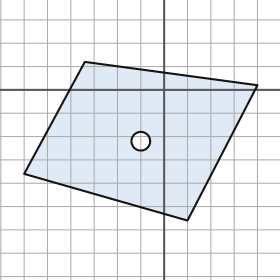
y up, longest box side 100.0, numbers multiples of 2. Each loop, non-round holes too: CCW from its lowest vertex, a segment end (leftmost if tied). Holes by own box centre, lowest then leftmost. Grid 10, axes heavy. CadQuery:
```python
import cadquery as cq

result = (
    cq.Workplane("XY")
    .moveTo(10.0, -56.0)
    .lineTo(40.0, 2.0)
    .lineTo(-34.0, 12.0)
    .lineTo(-60.0, -36.0)
    .close()
    .moveTo(-10.0, -22.0)
    .circle(4.0)
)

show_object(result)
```